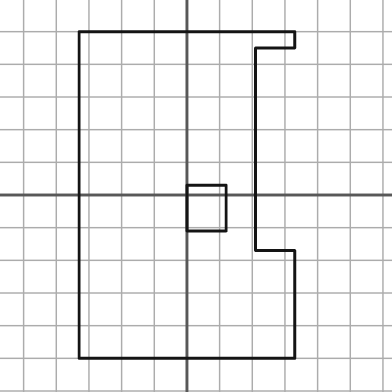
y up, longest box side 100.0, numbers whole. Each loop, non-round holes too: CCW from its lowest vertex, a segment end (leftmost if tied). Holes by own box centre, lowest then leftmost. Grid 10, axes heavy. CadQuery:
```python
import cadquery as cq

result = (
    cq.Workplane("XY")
    .moveTo(-33.0, -50.0)
    .lineTo(33.0, -50.0)
    .lineTo(33.0, -17.0)
    .lineTo(21.0, -17.0)
    .lineTo(21.0, 45.0)
    .lineTo(33.0, 45.0)
    .lineTo(33.0, 50.0)
    .lineTo(-33.0, 50.0)
    .close()
    .moveTo(0.0, -11.0)
    .lineTo(12.0, -11.0)
    .lineTo(12.0, 3.0)
    .lineTo(0.0, 3.0)
    .close()
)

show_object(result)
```